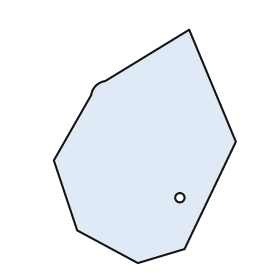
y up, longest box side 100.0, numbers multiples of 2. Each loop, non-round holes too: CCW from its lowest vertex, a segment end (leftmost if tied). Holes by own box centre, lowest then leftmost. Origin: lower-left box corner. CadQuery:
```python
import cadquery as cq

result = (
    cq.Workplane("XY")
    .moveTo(36.0, 0.0)
    .lineTo(56.0, 6.0)
    .lineTo(78.0, 52.0)
    .lineTo(58.0, 100.0)
    .lineTo(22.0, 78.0)
    .threePointArc((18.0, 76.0), (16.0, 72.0))
    .lineTo(0.0, 44.0)
    .lineTo(10.0, 14.0)
    .close()
    .moveTo(54.0, 28.0)
    .circle(2.0)
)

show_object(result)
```